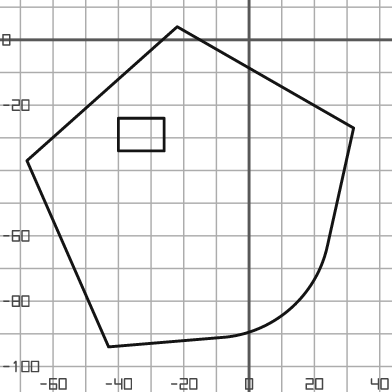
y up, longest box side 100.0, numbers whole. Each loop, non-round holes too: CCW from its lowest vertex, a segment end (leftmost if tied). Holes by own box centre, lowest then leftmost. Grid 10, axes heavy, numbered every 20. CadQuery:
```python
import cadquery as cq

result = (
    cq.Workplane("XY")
    .moveTo(-43.0, -94.0)
    .lineTo(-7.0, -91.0)
    .threePointArc((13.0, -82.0), (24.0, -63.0))
    .lineTo(32.0, -27.0)
    .lineTo(-22.0, 4.0)
    .lineTo(-68.0, -37.0)
    .close()
    .moveTo(-40.0, -34.0)
    .lineTo(-26.0, -34.0)
    .lineTo(-26.0, -24.0)
    .lineTo(-40.0, -24.0)
    .close()
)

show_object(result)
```